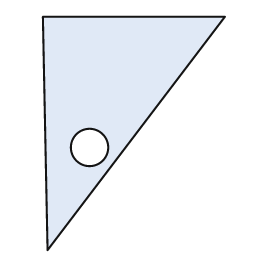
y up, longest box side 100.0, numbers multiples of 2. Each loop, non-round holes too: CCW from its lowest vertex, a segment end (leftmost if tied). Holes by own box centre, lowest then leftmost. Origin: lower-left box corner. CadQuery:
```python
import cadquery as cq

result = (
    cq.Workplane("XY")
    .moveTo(2.0, 0.0)
    .lineTo(78.0, 100.0)
    .lineTo(0.0, 100.0)
    .close()
    .moveTo(20.0, 44.0)
    .circle(8.0)
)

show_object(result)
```